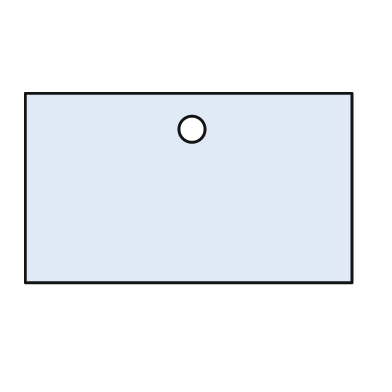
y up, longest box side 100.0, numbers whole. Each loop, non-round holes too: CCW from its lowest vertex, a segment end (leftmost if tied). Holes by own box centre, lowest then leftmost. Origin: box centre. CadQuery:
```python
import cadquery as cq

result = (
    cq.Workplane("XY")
    .moveTo(-50.0, -29.0)
    .lineTo(50.0, -29.0)
    .lineTo(50.0, 29.0)
    .lineTo(-50.0, 29.0)
    .close()
    .moveTo(1.0, 18.0)
    .circle(4.0)
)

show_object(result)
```